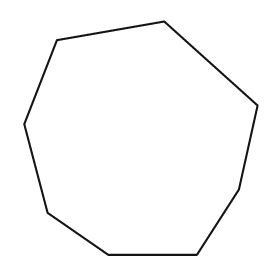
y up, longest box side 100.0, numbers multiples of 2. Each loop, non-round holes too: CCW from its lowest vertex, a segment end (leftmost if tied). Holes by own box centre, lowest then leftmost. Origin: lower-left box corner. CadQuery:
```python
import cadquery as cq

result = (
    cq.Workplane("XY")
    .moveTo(36.0, 0.0)
    .lineTo(74.0, 0.0)
    .lineTo(92.0, 28.0)
    .lineTo(100.0, 64.0)
    .lineTo(60.0, 100.0)
    .lineTo(14.0, 92.0)
    .lineTo(0.0, 56.0)
    .lineTo(10.0, 18.0)
    .close()
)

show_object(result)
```